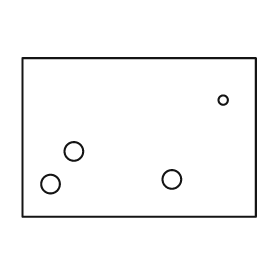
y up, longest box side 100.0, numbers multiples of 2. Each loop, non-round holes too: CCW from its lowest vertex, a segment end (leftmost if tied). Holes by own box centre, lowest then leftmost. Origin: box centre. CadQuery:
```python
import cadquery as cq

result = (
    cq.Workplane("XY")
    .moveTo(-50.0, -34.0)
    .lineTo(50.0, -34.0)
    .lineTo(50.0, 34.0)
    .lineTo(-50.0, 34.0)
    .close()
    .moveTo(-38.0, -20.0)
    .circle(4.0)
    .moveTo(14.0, -18.0)
    .circle(4.0)
    .moveTo(-28.0, -6.0)
    .circle(4.0)
    .moveTo(36.0, 16.0)
    .circle(2.0)
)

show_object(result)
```